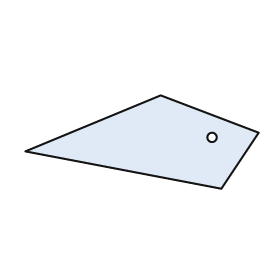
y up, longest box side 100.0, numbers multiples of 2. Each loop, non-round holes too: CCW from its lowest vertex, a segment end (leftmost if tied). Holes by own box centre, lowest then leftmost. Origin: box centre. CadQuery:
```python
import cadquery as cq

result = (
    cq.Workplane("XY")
    .moveTo(34.0, -20.0)
    .lineTo(50.0, 4.0)
    .lineTo(8.0, 20.0)
    .lineTo(-50.0, -4.0)
    .close()
    .moveTo(30.0, 2.0)
    .circle(2.0)
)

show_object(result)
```